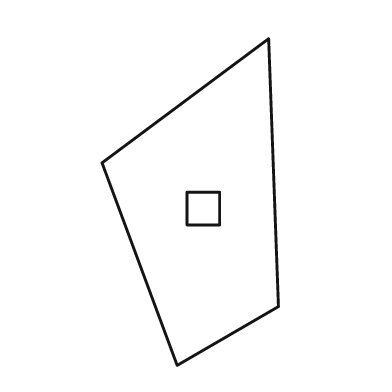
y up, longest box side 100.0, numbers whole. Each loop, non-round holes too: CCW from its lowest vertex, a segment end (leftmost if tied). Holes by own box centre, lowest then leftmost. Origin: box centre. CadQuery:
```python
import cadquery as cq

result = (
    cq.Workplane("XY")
    .moveTo(-4.0, -50.0)
    .lineTo(27.0, -32.0)
    .lineTo(24.0, 50.0)
    .lineTo(-27.0, 12.0)
    .close()
    .moveTo(-1.0, -7.0)
    .lineTo(9.0, -7.0)
    .lineTo(9.0, 3.0)
    .lineTo(-1.0, 3.0)
    .close()
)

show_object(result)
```